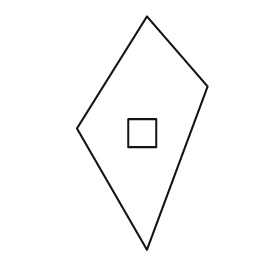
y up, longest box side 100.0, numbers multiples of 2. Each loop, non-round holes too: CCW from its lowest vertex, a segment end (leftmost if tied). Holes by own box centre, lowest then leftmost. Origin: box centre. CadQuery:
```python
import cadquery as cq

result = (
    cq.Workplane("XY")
    .moveTo(2.0, -50.0)
    .lineTo(28.0, 20.0)
    .lineTo(2.0, 50.0)
    .lineTo(-28.0, 2.0)
    .close()
    .moveTo(-6.0, -6.0)
    .lineTo(6.0, -6.0)
    .lineTo(6.0, 6.0)
    .lineTo(-6.0, 6.0)
    .close()
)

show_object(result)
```